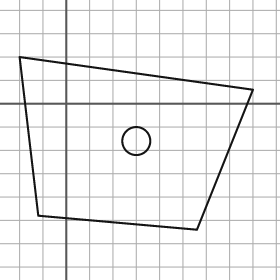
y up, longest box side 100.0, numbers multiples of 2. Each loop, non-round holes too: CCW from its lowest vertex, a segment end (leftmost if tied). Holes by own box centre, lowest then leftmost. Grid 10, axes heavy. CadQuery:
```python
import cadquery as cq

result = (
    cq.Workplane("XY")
    .moveTo(56.0, -54.0)
    .lineTo(80.0, 6.0)
    .lineTo(-20.0, 20.0)
    .lineTo(-12.0, -48.0)
    .close()
    .moveTo(30.0, -16.0)
    .circle(6.0)
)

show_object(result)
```